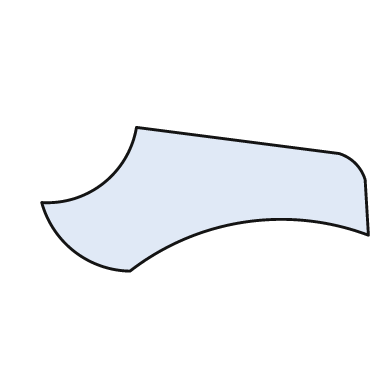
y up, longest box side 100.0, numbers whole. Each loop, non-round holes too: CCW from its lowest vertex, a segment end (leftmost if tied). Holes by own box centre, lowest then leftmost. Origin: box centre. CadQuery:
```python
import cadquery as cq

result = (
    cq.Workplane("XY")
    .moveTo(-23.0, -22.0)
    .threePointArc((12.0, -7.0), (50.0, -11.0))
    .lineTo(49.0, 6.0)
    .threePointArc((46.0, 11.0), (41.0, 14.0))
    .lineTo(-21.0, 22.0)
    .threePointArc((-31.0, 5.0), (-50.0, -1.0))
    .threePointArc((-40.0, -16.0), (-23.0, -22.0))
    .close()
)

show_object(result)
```